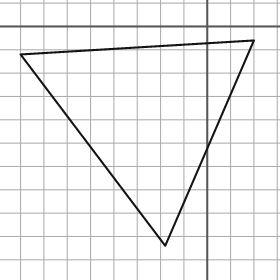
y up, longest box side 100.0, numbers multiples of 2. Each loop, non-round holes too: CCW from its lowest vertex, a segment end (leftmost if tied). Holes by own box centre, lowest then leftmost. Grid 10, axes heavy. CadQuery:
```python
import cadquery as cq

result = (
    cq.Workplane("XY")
    .moveTo(-18.0, -94.0)
    .lineTo(20.0, -6.0)
    .lineTo(-80.0, -12.0)
    .close()
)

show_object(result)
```